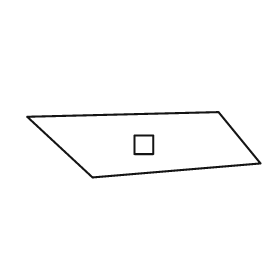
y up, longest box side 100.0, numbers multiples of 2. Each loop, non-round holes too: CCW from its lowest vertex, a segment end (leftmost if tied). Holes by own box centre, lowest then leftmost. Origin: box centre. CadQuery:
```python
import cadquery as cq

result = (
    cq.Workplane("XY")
    .moveTo(-22.0, -14.0)
    .lineTo(50.0, -8.0)
    .lineTo(32.0, 14.0)
    .lineTo(-50.0, 12.0)
    .close()
    .moveTo(-4.0, -4.0)
    .lineTo(4.0, -4.0)
    .lineTo(4.0, 4.0)
    .lineTo(-4.0, 4.0)
    .close()
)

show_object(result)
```